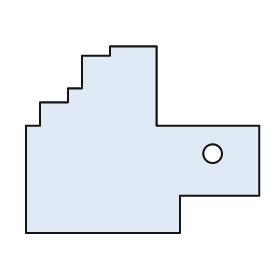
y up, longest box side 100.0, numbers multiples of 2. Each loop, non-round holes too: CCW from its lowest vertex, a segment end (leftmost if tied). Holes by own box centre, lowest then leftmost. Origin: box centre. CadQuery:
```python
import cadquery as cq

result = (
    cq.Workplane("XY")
    .moveTo(-50.0, -40.0)
    .lineTo(16.0, -40.0)
    .lineTo(16.0, -24.0)
    .lineTo(50.0, -24.0)
    .lineTo(50.0, 6.0)
    .lineTo(6.0, 6.0)
    .lineTo(6.0, 40.0)
    .lineTo(-14.0, 40.0)
    .lineTo(-14.0, 36.0)
    .lineTo(-26.0, 36.0)
    .lineTo(-26.0, 22.0)
    .lineTo(-32.0, 22.0)
    .lineTo(-32.0, 16.0)
    .lineTo(-44.0, 16.0)
    .lineTo(-44.0, 6.0)
    .lineTo(-50.0, 6.0)
    .close()
    .moveTo(30.0, -6.0)
    .circle(4.0)
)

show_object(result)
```